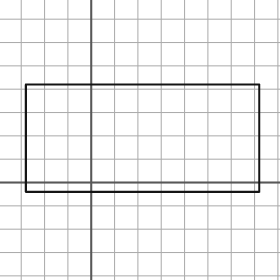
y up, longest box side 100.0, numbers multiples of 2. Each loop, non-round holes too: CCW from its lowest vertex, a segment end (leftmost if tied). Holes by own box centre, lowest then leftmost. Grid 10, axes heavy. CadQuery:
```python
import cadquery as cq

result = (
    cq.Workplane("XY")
    .moveTo(-28.0, -4.0)
    .lineTo(72.0, -4.0)
    .lineTo(72.0, 42.0)
    .lineTo(-28.0, 42.0)
    .close()
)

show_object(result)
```